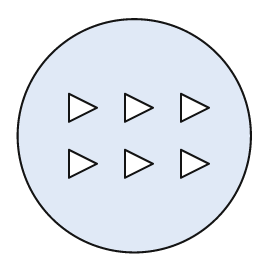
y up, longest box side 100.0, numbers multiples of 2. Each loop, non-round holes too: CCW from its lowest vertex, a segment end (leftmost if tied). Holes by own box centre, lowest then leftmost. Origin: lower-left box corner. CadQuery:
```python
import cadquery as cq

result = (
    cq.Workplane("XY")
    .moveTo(50.0, 50.0)
    .circle(50.0)
    .moveTo(22.0, 32.0)
    .lineTo(34.0, 38.0)
    .lineTo(22.0, 44.0)
    .close()
    .moveTo(46.0, 32.0)
    .lineTo(58.0, 38.0)
    .lineTo(46.0, 44.0)
    .close()
    .moveTo(70.0, 32.0)
    .lineTo(82.0, 38.0)
    .lineTo(70.0, 44.0)
    .close()
    .moveTo(22.0, 56.0)
    .lineTo(34.0, 62.0)
    .lineTo(22.0, 68.0)
    .close()
    .moveTo(46.0, 56.0)
    .lineTo(58.0, 62.0)
    .lineTo(46.0, 68.0)
    .close()
    .moveTo(70.0, 56.0)
    .lineTo(82.0, 62.0)
    .lineTo(70.0, 68.0)
    .close()
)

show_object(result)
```